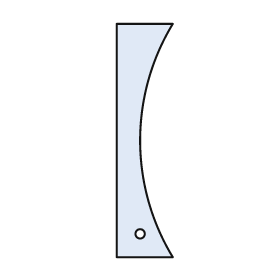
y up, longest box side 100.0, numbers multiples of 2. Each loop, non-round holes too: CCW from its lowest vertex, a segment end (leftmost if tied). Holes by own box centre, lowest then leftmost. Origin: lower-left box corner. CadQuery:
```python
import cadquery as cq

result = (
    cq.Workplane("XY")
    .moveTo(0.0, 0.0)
    .lineTo(24.0, 0.0)
    .threePointArc((10.0, 50.0), (24.0, 100.0))
    .lineTo(0.0, 100.0)
    .close()
    .moveTo(10.0, 10.0)
    .circle(2.0)
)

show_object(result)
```